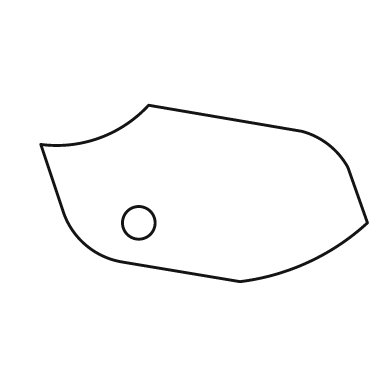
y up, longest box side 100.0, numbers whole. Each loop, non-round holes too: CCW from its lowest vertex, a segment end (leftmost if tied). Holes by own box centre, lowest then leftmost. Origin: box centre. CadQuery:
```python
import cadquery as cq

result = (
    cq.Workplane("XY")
    .moveTo(11.0, -27.0)
    .threePointArc((32.0, -21.0), (50.0, -9.0))
    .lineTo(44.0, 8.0)
    .threePointArc((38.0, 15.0), (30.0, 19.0))
    .lineTo(-17.0, 27.0)
    .threePointArc((-32.0, 17.0), (-50.0, 15.0))
    .lineTo(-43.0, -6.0)
    .threePointArc((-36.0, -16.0), (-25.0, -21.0))
    .close()
    .moveTo(-20.0, -9.0)
    .circle(5.0)
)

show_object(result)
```